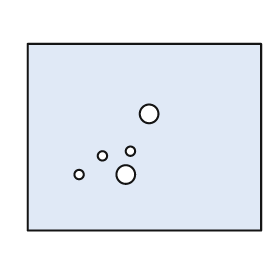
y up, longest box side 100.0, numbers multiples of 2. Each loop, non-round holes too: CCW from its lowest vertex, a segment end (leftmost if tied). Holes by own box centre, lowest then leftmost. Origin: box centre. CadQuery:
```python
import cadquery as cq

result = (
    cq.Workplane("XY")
    .moveTo(-50.0, -40.0)
    .lineTo(50.0, -40.0)
    .lineTo(50.0, 40.0)
    .lineTo(-50.0, 40.0)
    .close()
    .moveTo(-28.0, -16.0)
    .circle(2.0)
    .moveTo(-8.0, -16.0)
    .circle(4.0)
    .moveTo(-18.0, -8.0)
    .circle(2.0)
    .moveTo(-6.0, -6.0)
    .circle(2.0)
    .moveTo(2.0, 10.0)
    .circle(4.0)
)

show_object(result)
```